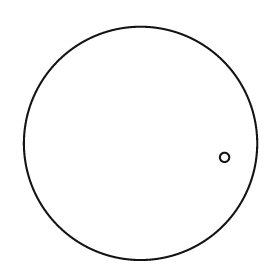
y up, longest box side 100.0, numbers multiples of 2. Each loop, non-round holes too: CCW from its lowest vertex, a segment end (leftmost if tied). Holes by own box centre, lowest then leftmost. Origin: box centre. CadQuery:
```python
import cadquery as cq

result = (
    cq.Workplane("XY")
    .moveTo(0.0, 0.0)
    .circle(50.0)
    .moveTo(36.0, -6.0)
    .circle(2.0)
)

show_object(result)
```